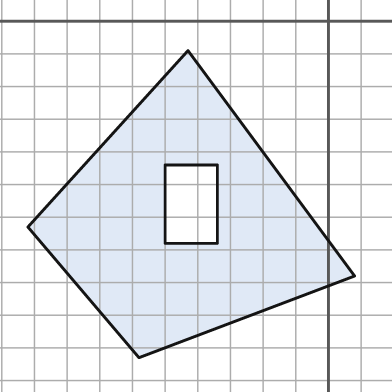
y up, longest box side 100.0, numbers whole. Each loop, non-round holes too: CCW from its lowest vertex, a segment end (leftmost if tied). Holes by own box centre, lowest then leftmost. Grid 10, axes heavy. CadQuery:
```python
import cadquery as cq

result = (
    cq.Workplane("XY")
    .moveTo(-58.0, -103.0)
    .lineTo(8.0, -78.0)
    .lineTo(-43.0, -9.0)
    .lineTo(-92.0, -63.0)
    .close()
    .moveTo(-50.0, -68.0)
    .lineTo(-34.0, -68.0)
    .lineTo(-34.0, -44.0)
    .lineTo(-50.0, -44.0)
    .close()
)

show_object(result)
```